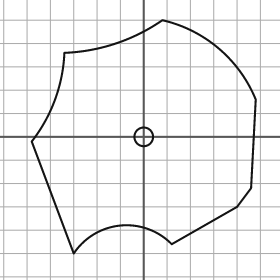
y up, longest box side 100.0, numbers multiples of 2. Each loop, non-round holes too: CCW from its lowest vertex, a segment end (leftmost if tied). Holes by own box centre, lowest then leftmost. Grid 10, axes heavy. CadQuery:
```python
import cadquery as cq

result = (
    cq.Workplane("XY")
    .moveTo(-30.0, -50.0)
    .threePointArc((-10.0, -38.0), (12.0, -46.0))
    .lineTo(40.0, -30.0)
    .lineTo(46.0, -22.0)
    .lineTo(48.0, 16.0)
    .threePointArc((32.0, 38.0), (8.0, 50.0))
    .threePointArc((-12.0, 40.0), (-34.0, 36.0))
    .threePointArc((-38.0, 16.0), (-48.0, -2.0))
    .close()
    .moveTo(0.0, 0.0)
    .circle(4.0)
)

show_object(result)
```